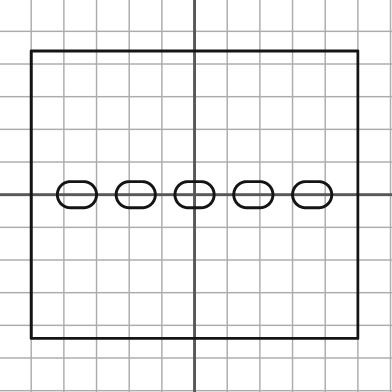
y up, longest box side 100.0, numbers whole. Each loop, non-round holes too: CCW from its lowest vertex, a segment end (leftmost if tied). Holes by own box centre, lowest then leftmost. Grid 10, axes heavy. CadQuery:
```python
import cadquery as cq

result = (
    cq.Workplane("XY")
    .moveTo(-50.0, -44.0)
    .lineTo(50.0, -44.0)
    .lineTo(50.0, 44.0)
    .lineTo(-50.0, 44.0)
    .close()
    .moveTo(-38.0, -4.0)
    .lineTo(-34.0, -4.0)
    .threePointArc((-30.0, 0.0), (-34.0, 4.0))
    .lineTo(-38.0, 4.0)
    .threePointArc((-42.0, 0.0), (-38.0, -4.0))
    .close()
    .moveTo(-20.0, -4.0)
    .lineTo(-16.0, -4.0)
    .threePointArc((-12.0, 0.0), (-16.0, 4.0))
    .lineTo(-20.0, 4.0)
    .threePointArc((-24.0, 0.0), (-20.0, -4.0))
    .close()
    .moveTo(-2.0, -4.0)
    .lineTo(2.0, -4.0)
    .threePointArc((6.0, 0.0), (2.0, 4.0))
    .lineTo(-2.0, 4.0)
    .threePointArc((-6.0, 0.0), (-2.0, -4.0))
    .close()
    .moveTo(16.0, -4.0)
    .lineTo(20.0, -4.0)
    .threePointArc((24.0, 0.0), (20.0, 4.0))
    .lineTo(16.0, 4.0)
    .threePointArc((12.0, 0.0), (16.0, -4.0))
    .close()
    .moveTo(34.0, -4.0)
    .lineTo(38.0, -4.0)
    .threePointArc((42.0, 0.0), (38.0, 4.0))
    .lineTo(34.0, 4.0)
    .threePointArc((30.0, 0.0), (34.0, -4.0))
    .close()
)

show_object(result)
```